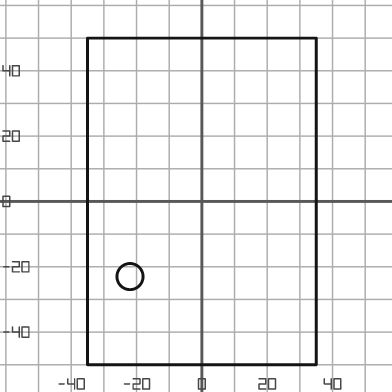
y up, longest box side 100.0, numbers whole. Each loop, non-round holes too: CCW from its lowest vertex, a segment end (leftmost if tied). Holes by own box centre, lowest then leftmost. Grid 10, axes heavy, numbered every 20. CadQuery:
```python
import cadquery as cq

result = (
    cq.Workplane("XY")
    .moveTo(-35.0, -50.0)
    .lineTo(35.0, -50.0)
    .lineTo(35.0, 50.0)
    .lineTo(-35.0, 50.0)
    .close()
    .moveTo(-22.0, -23.0)
    .circle(4.0)
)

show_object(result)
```